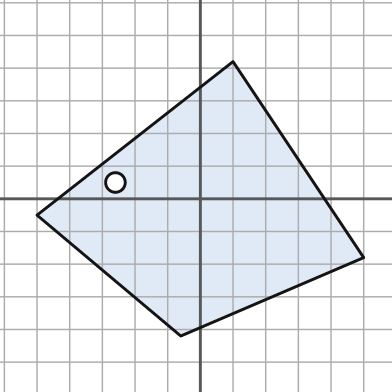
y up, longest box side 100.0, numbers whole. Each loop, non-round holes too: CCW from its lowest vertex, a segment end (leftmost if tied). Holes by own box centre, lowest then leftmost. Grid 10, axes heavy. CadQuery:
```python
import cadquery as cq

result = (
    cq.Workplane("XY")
    .moveTo(-6.0, -42.0)
    .lineTo(50.0, -18.0)
    .lineTo(10.0, 42.0)
    .lineTo(-50.0, -5.0)
    .close()
    .moveTo(-26.0, 5.0)
    .circle(3.0)
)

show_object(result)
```